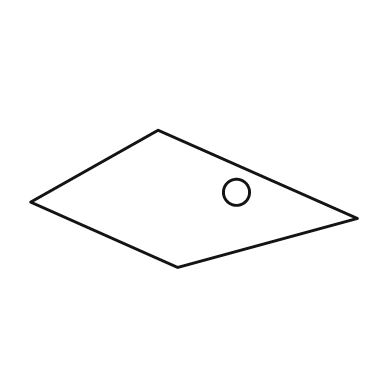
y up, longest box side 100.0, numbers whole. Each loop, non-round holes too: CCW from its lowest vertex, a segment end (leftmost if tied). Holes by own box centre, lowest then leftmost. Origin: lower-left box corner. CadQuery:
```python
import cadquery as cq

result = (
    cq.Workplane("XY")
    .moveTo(45.0, 0.0)
    .lineTo(100.0, 15.0)
    .lineTo(39.0, 42.0)
    .lineTo(0.0, 20.0)
    .close()
    .moveTo(63.0, 23.0)
    .circle(4.0)
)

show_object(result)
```